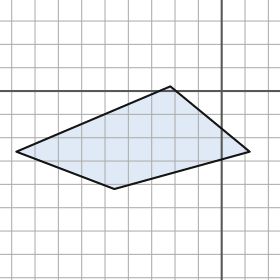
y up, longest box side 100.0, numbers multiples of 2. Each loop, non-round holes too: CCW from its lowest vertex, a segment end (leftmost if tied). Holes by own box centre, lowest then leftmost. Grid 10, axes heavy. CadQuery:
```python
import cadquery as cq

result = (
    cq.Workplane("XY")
    .moveTo(-46.0, -42.0)
    .lineTo(12.0, -26.0)
    .lineTo(-22.0, 2.0)
    .lineTo(-88.0, -26.0)
    .close()
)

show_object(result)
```